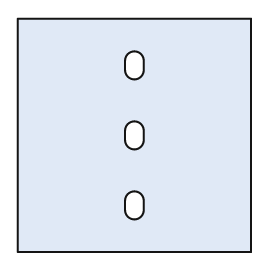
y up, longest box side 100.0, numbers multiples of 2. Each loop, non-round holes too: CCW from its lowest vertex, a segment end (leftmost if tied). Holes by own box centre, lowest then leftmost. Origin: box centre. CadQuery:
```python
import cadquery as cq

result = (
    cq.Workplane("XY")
    .moveTo(-50.0, -50.0)
    .lineTo(50.0, -50.0)
    .lineTo(50.0, 50.0)
    .lineTo(-50.0, 50.0)
    .close()
    .moveTo(-4.0, -32.0)
    .threePointArc((0.0, -36.0), (4.0, -32.0))
    .lineTo(4.0, -28.0)
    .threePointArc((0.0, -24.0), (-4.0, -28.0))
    .close()
    .moveTo(-4.0, -2.0)
    .threePointArc((0.0, -6.0), (4.0, -2.0))
    .lineTo(4.0, 2.0)
    .threePointArc((0.0, 6.0), (-4.0, 2.0))
    .close()
    .moveTo(-4.0, 28.0)
    .threePointArc((0.0, 24.0), (4.0, 28.0))
    .lineTo(4.0, 32.0)
    .threePointArc((0.0, 36.0), (-4.0, 32.0))
    .close()
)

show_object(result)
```